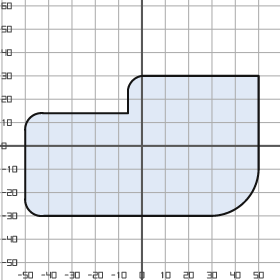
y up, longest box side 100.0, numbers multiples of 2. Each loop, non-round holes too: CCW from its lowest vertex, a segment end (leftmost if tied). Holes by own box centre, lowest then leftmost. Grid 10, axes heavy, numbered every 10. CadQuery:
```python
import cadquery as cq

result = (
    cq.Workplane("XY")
    .moveTo(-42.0, -30.0)
    .lineTo(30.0, -30.0)
    .threePointArc((44.0, -24.0), (50.0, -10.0))
    .lineTo(50.0, 30.0)
    .lineTo(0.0, 30.0)
    .threePointArc((-4.0, 28.0), (-6.0, 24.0))
    .lineTo(-6.0, 14.0)
    .lineTo(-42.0, 14.0)
    .threePointArc((-48.0, 12.0), (-50.0, 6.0))
    .lineTo(-50.0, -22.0)
    .threePointArc((-48.0, -28.0), (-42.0, -30.0))
    .close()
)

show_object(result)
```